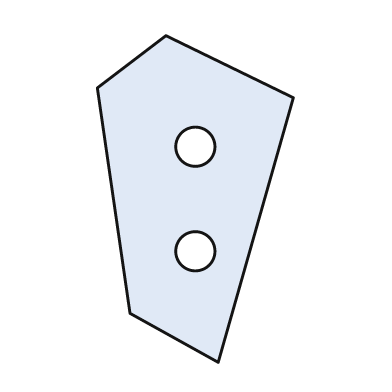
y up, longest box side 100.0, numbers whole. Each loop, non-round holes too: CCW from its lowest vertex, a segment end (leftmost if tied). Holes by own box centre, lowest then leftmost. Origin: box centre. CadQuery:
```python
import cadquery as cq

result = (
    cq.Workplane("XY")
    .moveTo(7.0, -50.0)
    .lineTo(30.0, 31.0)
    .lineTo(-9.0, 50.0)
    .lineTo(-30.0, 34.0)
    .lineTo(-20.0, -35.0)
    .close()
    .moveTo(0.0, -16.0)
    .circle(6.0)
    .moveTo(0.0, 16.0)
    .circle(6.0)
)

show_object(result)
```